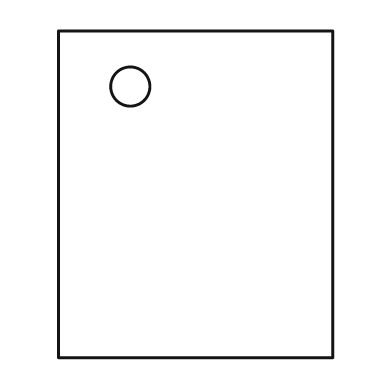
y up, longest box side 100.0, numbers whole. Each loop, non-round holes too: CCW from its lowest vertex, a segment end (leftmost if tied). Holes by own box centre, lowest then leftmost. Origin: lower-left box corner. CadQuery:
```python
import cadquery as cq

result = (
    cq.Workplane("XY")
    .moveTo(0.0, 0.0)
    .lineTo(84.0, 0.0)
    .lineTo(84.0, 100.0)
    .lineTo(0.0, 100.0)
    .close()
    .moveTo(22.0, 83.0)
    .circle(6.0)
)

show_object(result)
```